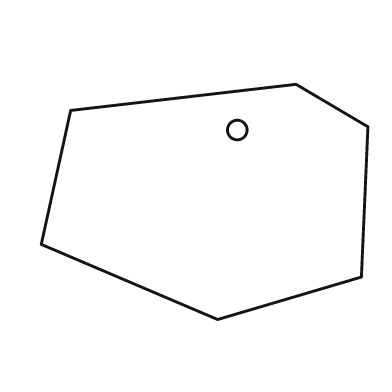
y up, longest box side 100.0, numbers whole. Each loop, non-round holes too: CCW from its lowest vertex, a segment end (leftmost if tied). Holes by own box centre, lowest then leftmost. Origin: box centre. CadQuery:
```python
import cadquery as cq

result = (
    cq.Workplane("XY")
    .moveTo(4.0, -36.0)
    .lineTo(48.0, -23.0)
    .lineTo(50.0, 23.0)
    .lineTo(28.0, 36.0)
    .lineTo(-41.0, 28.0)
    .lineTo(-50.0, -13.0)
    .close()
    .moveTo(10.0, 22.0)
    .circle(3.0)
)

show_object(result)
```